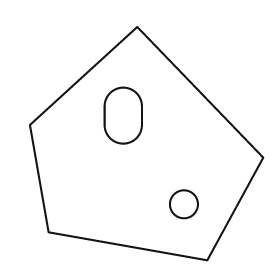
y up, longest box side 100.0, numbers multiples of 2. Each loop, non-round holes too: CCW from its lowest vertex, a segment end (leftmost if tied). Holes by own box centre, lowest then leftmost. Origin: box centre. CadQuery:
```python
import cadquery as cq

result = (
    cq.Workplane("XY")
    .moveTo(26.0, -50.0)
    .lineTo(50.0, -6.0)
    .lineTo(-4.0, 50.0)
    .lineTo(-50.0, 8.0)
    .lineTo(-42.0, -38.0)
    .close()
    .moveTo(16.0, -26.0)
    .circle(6.0)
    .moveTo(-18.0, 8.0)
    .threePointArc((-10.0, 0.0), (-2.0, 8.0))
    .lineTo(-2.0, 16.0)
    .threePointArc((-10.0, 24.0), (-18.0, 16.0))
    .close()
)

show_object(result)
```